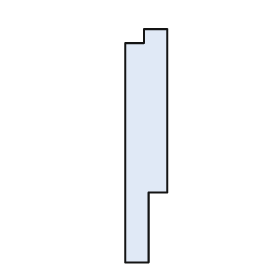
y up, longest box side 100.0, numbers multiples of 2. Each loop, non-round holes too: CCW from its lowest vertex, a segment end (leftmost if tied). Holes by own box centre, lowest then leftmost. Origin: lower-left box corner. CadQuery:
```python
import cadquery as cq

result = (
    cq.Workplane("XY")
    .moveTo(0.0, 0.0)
    .lineTo(10.0, 0.0)
    .lineTo(10.0, 30.0)
    .lineTo(18.0, 30.0)
    .lineTo(18.0, 100.0)
    .lineTo(8.0, 100.0)
    .lineTo(8.0, 94.0)
    .lineTo(0.0, 94.0)
    .close()
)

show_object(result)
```